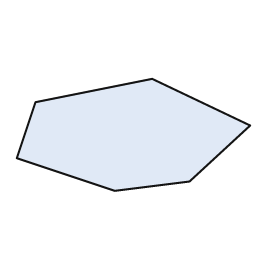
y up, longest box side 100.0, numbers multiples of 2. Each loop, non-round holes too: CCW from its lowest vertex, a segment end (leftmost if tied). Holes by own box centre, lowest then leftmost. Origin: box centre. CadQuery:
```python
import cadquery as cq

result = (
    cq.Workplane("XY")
    .moveTo(-8.0, -24.0)
    .lineTo(24.0, -20.0)
    .lineTo(50.0, 4.0)
    .lineTo(8.0, 24.0)
    .lineTo(-42.0, 14.0)
    .lineTo(-50.0, -10.0)
    .close()
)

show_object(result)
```